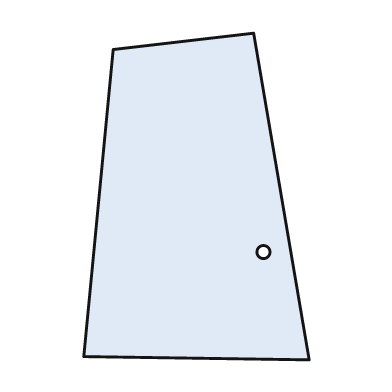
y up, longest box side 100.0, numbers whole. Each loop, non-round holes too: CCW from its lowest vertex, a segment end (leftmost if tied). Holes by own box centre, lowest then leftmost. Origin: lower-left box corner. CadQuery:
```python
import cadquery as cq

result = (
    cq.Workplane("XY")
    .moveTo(69.0, 0.0)
    .lineTo(52.0, 100.0)
    .lineTo(9.0, 95.0)
    .lineTo(0.0, 1.0)
    .close()
    .moveTo(55.0, 33.0)
    .circle(2.0)
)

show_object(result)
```